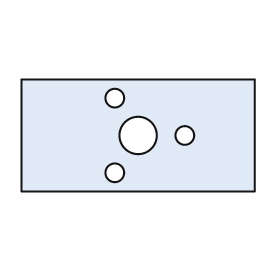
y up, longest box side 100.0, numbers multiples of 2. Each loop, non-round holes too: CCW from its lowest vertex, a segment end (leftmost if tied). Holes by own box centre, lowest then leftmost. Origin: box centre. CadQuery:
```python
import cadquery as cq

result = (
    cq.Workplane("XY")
    .moveTo(-50.0, -24.0)
    .lineTo(50.0, -24.0)
    .lineTo(50.0, 24.0)
    .lineTo(-50.0, 24.0)
    .close()
    .moveTo(-10.0, -16.0)
    .circle(4.0)
    .moveTo(0.0, 0.0)
    .circle(8.0)
    .moveTo(20.0, 0.0)
    .circle(4.0)
    .moveTo(-10.0, 16.0)
    .circle(4.0)
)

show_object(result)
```